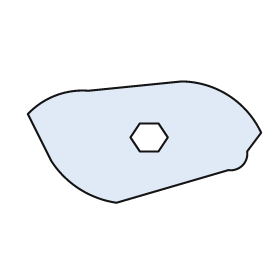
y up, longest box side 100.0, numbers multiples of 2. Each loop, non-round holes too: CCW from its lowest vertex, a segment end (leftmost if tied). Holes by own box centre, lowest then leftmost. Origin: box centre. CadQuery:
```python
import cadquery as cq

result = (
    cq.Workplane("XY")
    .moveTo(-12.0, -26.0)
    .lineTo(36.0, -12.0)
    .threePointArc((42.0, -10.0), (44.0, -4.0))
    .lineTo(50.0, 4.0)
    .threePointArc((36.0, 20.0), (16.0, 26.0))
    .lineTo(-24.0, 22.0)
    .threePointArc((-38.0, 20.0), (-50.0, 12.0))
    .lineTo(-40.0, -8.0)
    .threePointArc((-28.0, -20.0), (-12.0, -26.0))
    .close()
    .moveTo(-2.0, -4.0)
    .lineTo(6.0, -4.0)
    .lineTo(10.0, 2.0)
    .lineTo(6.0, 8.0)
    .lineTo(-2.0, 8.0)
    .lineTo(-6.0, 2.0)
    .close()
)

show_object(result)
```